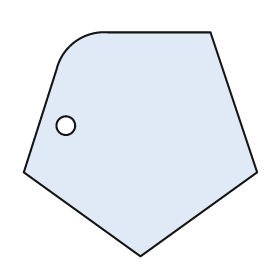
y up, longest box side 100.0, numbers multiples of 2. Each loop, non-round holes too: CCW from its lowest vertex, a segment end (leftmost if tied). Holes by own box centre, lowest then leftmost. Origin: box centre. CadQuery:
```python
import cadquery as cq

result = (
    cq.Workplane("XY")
    .moveTo(0.0, -48.0)
    .lineTo(50.0, -12.0)
    .lineTo(30.0, 48.0)
    .lineTo(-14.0, 48.0)
    .threePointArc((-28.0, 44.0), (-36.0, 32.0))
    .lineTo(-50.0, -12.0)
    .close()
    .moveTo(-32.0, 8.0)
    .circle(4.0)
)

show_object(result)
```